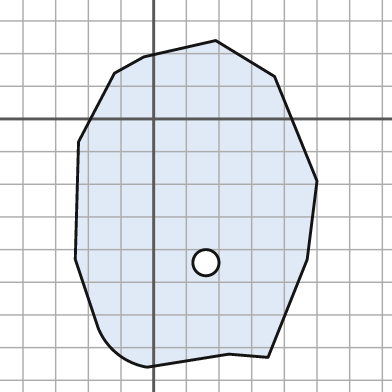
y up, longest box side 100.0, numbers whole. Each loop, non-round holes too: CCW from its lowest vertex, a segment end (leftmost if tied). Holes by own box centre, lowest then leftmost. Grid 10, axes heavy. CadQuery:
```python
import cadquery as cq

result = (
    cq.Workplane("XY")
    .moveTo(-2.0, -76.0)
    .lineTo(23.0, -72.0)
    .lineTo(35.0, -73.0)
    .lineTo(47.0, -43.0)
    .lineTo(50.0, -19.0)
    .lineTo(37.0, 13.0)
    .lineTo(19.0, 24.0)
    .lineTo(-3.0, 19.0)
    .lineTo(-12.0, 14.0)
    .lineTo(-23.0, -7.0)
    .lineTo(-24.0, -43.0)
    .lineTo(-17.0, -64.0)
    .threePointArc((-11.0, -72.0), (-2.0, -76.0))
    .close()
    .moveTo(16.0, -44.0)
    .circle(4.0)
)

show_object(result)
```